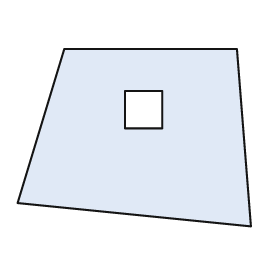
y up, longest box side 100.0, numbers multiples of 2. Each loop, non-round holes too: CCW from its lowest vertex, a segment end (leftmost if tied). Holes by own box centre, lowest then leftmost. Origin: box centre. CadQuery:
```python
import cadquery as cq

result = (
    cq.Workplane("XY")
    .moveTo(50.0, -38.0)
    .lineTo(44.0, 38.0)
    .lineTo(-30.0, 38.0)
    .lineTo(-50.0, -28.0)
    .close()
    .moveTo(-4.0, 4.0)
    .lineTo(12.0, 4.0)
    .lineTo(12.0, 20.0)
    .lineTo(-4.0, 20.0)
    .close()
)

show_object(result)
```